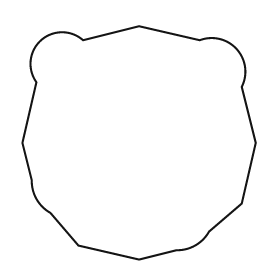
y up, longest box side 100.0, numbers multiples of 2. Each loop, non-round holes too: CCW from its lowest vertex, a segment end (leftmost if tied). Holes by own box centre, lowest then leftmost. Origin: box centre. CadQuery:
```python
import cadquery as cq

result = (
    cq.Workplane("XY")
    .moveTo(0.0, -50.0)
    .lineTo(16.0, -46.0)
    .threePointArc((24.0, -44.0), (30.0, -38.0))
    .lineTo(44.0, -26.0)
    .lineTo(50.0, 0.0)
    .lineTo(44.0, 24.0)
    .threePointArc((42.0, 40.0), (26.0, 44.0))
    .lineTo(0.0, 50.0)
    .lineTo(-24.0, 44.0)
    .threePointArc((-42.0, 44.0), (-44.0, 26.0))
    .lineTo(-50.0, 0.0)
    .lineTo(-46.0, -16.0)
    .threePointArc((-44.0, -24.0), (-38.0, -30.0))
    .lineTo(-26.0, -44.0)
    .close()
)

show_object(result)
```